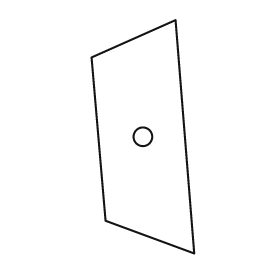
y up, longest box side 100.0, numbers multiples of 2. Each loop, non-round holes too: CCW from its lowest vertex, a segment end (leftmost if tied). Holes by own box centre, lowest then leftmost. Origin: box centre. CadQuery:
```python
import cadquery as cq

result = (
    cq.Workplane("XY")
    .moveTo(22.0, -50.0)
    .lineTo(14.0, 50.0)
    .lineTo(-22.0, 34.0)
    .lineTo(-16.0, -36.0)
    .close()
    .moveTo(0.0, 0.0)
    .circle(4.0)
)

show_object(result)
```